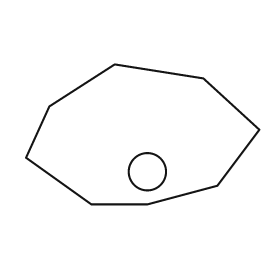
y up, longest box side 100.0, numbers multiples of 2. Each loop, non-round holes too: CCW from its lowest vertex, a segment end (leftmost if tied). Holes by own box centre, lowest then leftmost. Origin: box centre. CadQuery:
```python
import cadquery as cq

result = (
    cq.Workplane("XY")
    .moveTo(-22.0, -30.0)
    .lineTo(2.0, -30.0)
    .lineTo(32.0, -22.0)
    .lineTo(50.0, 2.0)
    .lineTo(26.0, 24.0)
    .lineTo(-12.0, 30.0)
    .lineTo(-40.0, 12.0)
    .lineTo(-50.0, -10.0)
    .close()
    .moveTo(2.0, -16.0)
    .circle(8.0)
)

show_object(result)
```